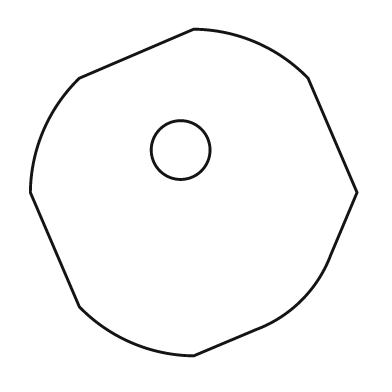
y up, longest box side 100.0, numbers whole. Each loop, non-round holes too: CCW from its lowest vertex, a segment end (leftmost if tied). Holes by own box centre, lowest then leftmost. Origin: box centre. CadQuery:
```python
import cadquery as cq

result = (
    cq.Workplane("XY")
    .moveTo(0.0, -50.0)
    .lineTo(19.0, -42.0)
    .threePointArc((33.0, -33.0), (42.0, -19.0))
    .lineTo(50.0, 0.0)
    .lineTo(35.0, 35.0)
    .threePointArc((19.0, 46.0), (0.0, 50.0))
    .lineTo(-35.0, 35.0)
    .threePointArc((-46.0, 19.0), (-50.0, 0.0))
    .lineTo(-35.0, -35.0)
    .threePointArc((-19.0, -46.0), (0.0, -50.0))
    .close()
    .moveTo(-4.0, 13.0)
    .circle(9.0)
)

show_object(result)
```